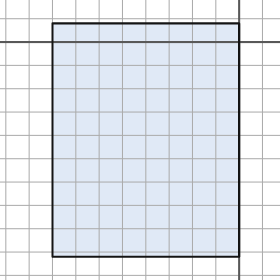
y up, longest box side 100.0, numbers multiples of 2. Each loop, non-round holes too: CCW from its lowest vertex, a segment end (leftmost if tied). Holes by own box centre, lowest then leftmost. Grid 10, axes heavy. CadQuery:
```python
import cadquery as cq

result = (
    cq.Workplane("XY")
    .moveTo(-80.0, -92.0)
    .lineTo(0.0, -92.0)
    .lineTo(0.0, 8.0)
    .lineTo(-80.0, 8.0)
    .close()
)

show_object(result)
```